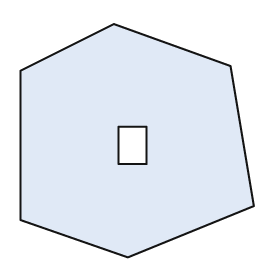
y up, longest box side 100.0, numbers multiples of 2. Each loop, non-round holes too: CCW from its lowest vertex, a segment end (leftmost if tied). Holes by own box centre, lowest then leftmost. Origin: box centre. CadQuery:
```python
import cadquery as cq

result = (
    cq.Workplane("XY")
    .moveTo(-4.0, -50.0)
    .lineTo(50.0, -28.0)
    .lineTo(40.0, 32.0)
    .lineTo(-10.0, 50.0)
    .lineTo(-50.0, 30.0)
    .lineTo(-50.0, -34.0)
    .close()
    .moveTo(-8.0, -10.0)
    .lineTo(4.0, -10.0)
    .lineTo(4.0, 6.0)
    .lineTo(-8.0, 6.0)
    .close()
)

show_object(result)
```